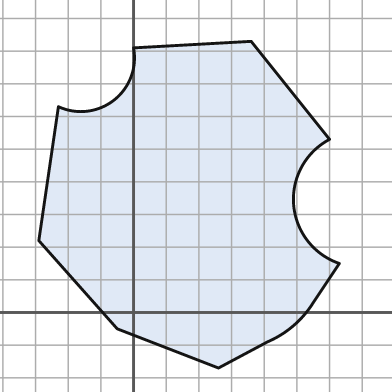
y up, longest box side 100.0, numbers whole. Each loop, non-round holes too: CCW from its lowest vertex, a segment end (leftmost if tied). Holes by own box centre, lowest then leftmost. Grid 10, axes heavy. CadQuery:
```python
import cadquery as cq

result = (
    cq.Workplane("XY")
    .moveTo(26.0, -17.0)
    .lineTo(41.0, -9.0)
    .threePointArc((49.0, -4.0), (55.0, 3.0))
    .lineTo(63.0, 15.0)
    .threePointArc((49.0, 33.0), (60.0, 53.0))
    .lineTo(36.0, 83.0)
    .lineTo(0.0, 81.0)
    .threePointArc((-6.0, 65.0), (-23.0, 63.0))
    .lineTo(-29.0, 22.0)
    .lineTo(-5.0, -5.0)
    .close()
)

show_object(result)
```